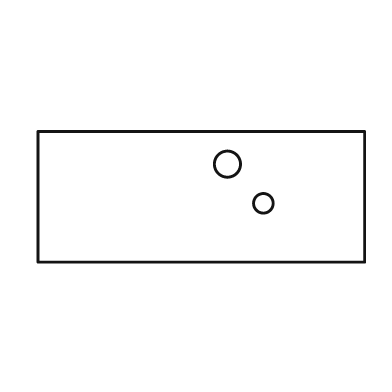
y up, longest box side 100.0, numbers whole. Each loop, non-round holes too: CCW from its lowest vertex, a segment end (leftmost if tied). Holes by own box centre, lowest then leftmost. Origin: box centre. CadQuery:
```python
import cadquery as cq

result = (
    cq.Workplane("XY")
    .moveTo(-50.0, -20.0)
    .lineTo(50.0, -20.0)
    .lineTo(50.0, 20.0)
    .lineTo(-50.0, 20.0)
    .close()
    .moveTo(19.0, -2.0)
    .circle(3.0)
    .moveTo(8.0, 10.0)
    .circle(4.0)
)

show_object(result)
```